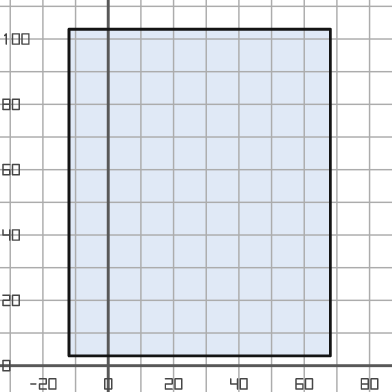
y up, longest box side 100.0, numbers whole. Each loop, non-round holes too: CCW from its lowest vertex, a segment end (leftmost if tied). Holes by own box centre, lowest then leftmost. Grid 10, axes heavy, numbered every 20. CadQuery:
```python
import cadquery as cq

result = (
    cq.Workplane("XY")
    .moveTo(-12.0, 3.0)
    .lineTo(68.0, 3.0)
    .lineTo(68.0, 103.0)
    .lineTo(-12.0, 103.0)
    .close()
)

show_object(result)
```